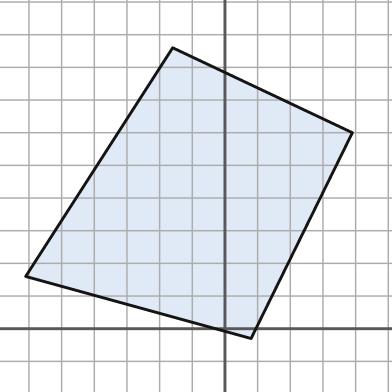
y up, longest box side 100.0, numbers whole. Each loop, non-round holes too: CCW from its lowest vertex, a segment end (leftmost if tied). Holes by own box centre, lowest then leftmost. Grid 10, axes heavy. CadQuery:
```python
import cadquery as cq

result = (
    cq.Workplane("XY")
    .moveTo(8.0, -3.0)
    .lineTo(39.0, 60.0)
    .lineTo(-16.0, 86.0)
    .lineTo(-61.0, 16.0)
    .close()
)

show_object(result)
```